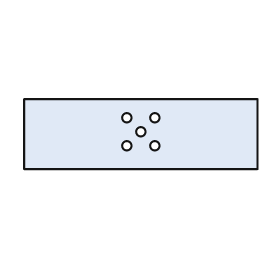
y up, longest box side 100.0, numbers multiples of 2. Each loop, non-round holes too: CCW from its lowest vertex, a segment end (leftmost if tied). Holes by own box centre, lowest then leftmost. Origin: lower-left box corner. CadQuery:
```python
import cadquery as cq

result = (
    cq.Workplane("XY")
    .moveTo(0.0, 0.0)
    .lineTo(100.0, 0.0)
    .lineTo(100.0, 30.0)
    .lineTo(0.0, 30.0)
    .close()
    .moveTo(44.0, 10.0)
    .circle(2.0)
    .moveTo(56.0, 10.0)
    .circle(2.0)
    .moveTo(50.0, 16.0)
    .circle(2.0)
    .moveTo(44.0, 22.0)
    .circle(2.0)
    .moveTo(56.0, 22.0)
    .circle(2.0)
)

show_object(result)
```